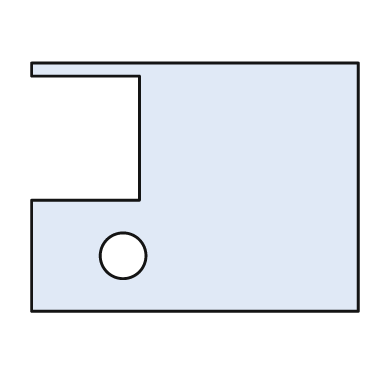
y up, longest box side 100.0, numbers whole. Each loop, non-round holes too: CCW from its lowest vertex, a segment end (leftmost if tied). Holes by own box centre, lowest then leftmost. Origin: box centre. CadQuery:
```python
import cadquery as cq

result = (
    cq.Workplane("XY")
    .moveTo(-50.0, -38.0)
    .lineTo(50.0, -38.0)
    .lineTo(50.0, 38.0)
    .lineTo(-50.0, 38.0)
    .lineTo(-50.0, 34.0)
    .lineTo(-17.0, 34.0)
    .lineTo(-17.0, -4.0)
    .lineTo(-50.0, -4.0)
    .close()
    .moveTo(-22.0, -21.0)
    .circle(7.0)
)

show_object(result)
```